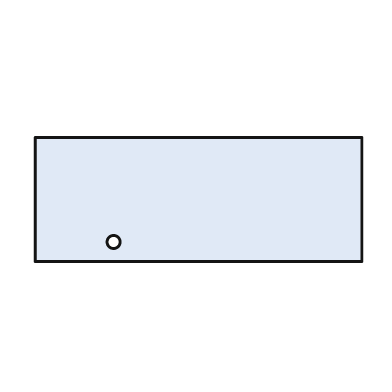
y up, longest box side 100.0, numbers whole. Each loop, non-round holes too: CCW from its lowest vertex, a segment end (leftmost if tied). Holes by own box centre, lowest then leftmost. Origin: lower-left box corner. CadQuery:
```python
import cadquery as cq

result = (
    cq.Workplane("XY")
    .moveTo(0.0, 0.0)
    .lineTo(100.0, 0.0)
    .lineTo(100.0, 38.0)
    .lineTo(0.0, 38.0)
    .close()
    .moveTo(24.0, 6.0)
    .circle(2.0)
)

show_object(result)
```